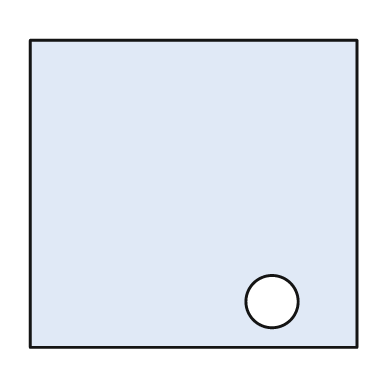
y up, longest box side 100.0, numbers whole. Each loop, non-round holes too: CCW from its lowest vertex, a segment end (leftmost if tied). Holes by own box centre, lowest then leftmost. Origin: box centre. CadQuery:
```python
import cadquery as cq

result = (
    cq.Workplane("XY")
    .moveTo(-50.0, -47.0)
    .lineTo(50.0, -47.0)
    .lineTo(50.0, 47.0)
    .lineTo(-50.0, 47.0)
    .close()
    .moveTo(24.0, -33.0)
    .circle(8.0)
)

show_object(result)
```